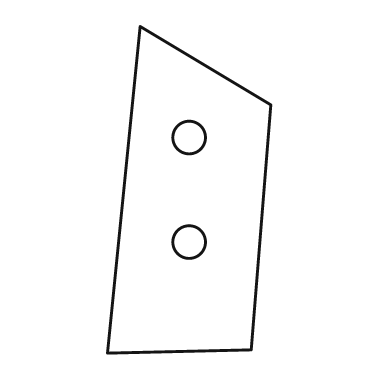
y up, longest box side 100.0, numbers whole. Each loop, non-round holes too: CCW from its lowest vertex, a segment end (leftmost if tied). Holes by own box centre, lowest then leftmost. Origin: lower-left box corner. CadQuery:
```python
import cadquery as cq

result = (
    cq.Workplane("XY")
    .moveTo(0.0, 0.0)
    .lineTo(44.0, 1.0)
    .lineTo(50.0, 76.0)
    .lineTo(10.0, 100.0)
    .close()
    .moveTo(25.0, 34.0)
    .circle(5.0)
    .moveTo(25.0, 66.0)
    .circle(5.0)
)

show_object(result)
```